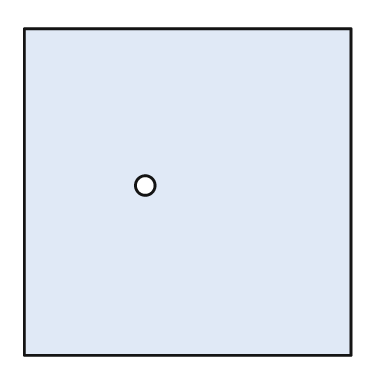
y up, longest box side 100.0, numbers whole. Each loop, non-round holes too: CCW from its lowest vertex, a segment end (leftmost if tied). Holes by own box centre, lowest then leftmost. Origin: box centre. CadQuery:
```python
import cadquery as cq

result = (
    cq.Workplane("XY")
    .moveTo(-50.0, -50.0)
    .lineTo(50.0, -50.0)
    .lineTo(50.0, 50.0)
    .lineTo(-50.0, 50.0)
    .close()
    .moveTo(-13.0, 2.0)
    .circle(3.0)
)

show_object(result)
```